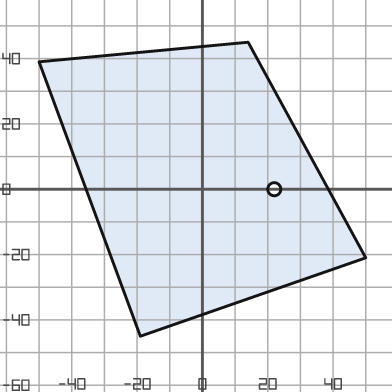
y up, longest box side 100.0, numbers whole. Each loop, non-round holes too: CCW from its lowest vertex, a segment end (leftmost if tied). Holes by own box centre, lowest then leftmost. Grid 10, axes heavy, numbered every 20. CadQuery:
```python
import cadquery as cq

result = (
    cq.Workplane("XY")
    .moveTo(-19.0, -45.0)
    .lineTo(50.0, -21.0)
    .lineTo(14.0, 45.0)
    .lineTo(-50.0, 39.0)
    .close()
    .moveTo(22.0, 0.0)
    .circle(2.0)
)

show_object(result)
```